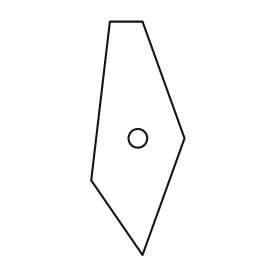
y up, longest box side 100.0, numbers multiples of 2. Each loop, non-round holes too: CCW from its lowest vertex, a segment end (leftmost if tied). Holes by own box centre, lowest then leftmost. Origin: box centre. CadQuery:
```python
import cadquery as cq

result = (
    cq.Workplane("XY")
    .moveTo(2.0, -50.0)
    .lineTo(20.0, 0.0)
    .lineTo(2.0, 50.0)
    .lineTo(-12.0, 50.0)
    .lineTo(-20.0, -18.0)
    .close()
    .moveTo(0.0, 0.0)
    .circle(4.0)
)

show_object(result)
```